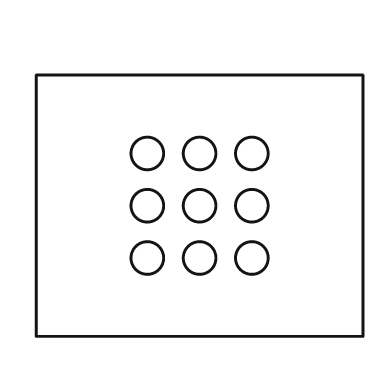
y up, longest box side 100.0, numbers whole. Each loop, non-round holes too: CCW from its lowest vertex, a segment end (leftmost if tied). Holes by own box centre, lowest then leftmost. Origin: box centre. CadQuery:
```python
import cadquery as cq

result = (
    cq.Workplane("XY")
    .moveTo(-50.0, -40.0)
    .lineTo(50.0, -40.0)
    .lineTo(50.0, 40.0)
    .lineTo(-50.0, 40.0)
    .close()
    .moveTo(-16.0, -16.0)
    .circle(5.0)
    .moveTo(0.0, -16.0)
    .circle(5.0)
    .moveTo(16.0, -16.0)
    .circle(5.0)
    .moveTo(-16.0, 0.0)
    .circle(5.0)
    .moveTo(0.0, 0.0)
    .circle(5.0)
    .moveTo(16.0, 0.0)
    .circle(5.0)
    .moveTo(-16.0, 16.0)
    .circle(5.0)
    .moveTo(0.0, 16.0)
    .circle(5.0)
    .moveTo(16.0, 16.0)
    .circle(5.0)
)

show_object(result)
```